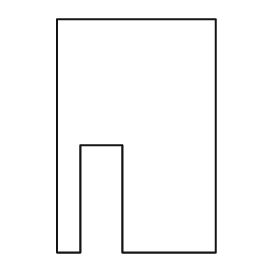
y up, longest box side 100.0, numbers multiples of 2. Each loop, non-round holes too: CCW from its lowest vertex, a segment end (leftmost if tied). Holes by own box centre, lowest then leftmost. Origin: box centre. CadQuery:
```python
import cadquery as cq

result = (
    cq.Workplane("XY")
    .moveTo(-34.0, -50.0)
    .lineTo(-24.0, -50.0)
    .lineTo(-24.0, -4.0)
    .lineTo(-6.0, -4.0)
    .lineTo(-6.0, -50.0)
    .lineTo(34.0, -50.0)
    .lineTo(34.0, 50.0)
    .lineTo(-34.0, 50.0)
    .close()
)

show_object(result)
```